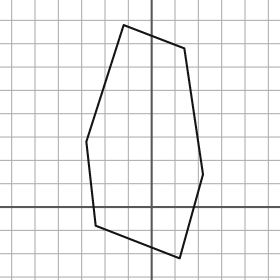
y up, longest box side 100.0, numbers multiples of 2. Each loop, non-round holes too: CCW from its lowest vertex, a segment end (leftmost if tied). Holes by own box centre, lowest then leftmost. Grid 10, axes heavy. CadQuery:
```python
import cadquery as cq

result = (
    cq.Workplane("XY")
    .moveTo(12.0, -22.0)
    .lineTo(22.0, 14.0)
    .lineTo(14.0, 68.0)
    .lineTo(-12.0, 78.0)
    .lineTo(-28.0, 28.0)
    .lineTo(-24.0, -8.0)
    .close()
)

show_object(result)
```